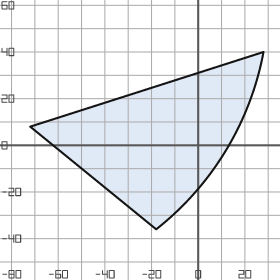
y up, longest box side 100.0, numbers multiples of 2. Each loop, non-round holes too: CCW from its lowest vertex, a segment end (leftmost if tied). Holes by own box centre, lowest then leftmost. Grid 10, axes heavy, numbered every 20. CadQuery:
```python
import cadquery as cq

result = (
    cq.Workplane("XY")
    .moveTo(-18.0, -36.0)
    .threePointArc((12.0, -2.0), (28.0, 40.0))
    .lineTo(-72.0, 8.0)
    .close()
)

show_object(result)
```